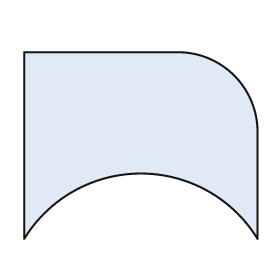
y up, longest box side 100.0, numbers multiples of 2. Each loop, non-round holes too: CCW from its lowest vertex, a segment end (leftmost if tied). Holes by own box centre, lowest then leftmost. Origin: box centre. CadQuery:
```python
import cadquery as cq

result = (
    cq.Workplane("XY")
    .moveTo(-50.0, -40.0)
    .threePointArc((0.0, -12.0), (50.0, -40.0))
    .lineTo(50.0, 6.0)
    .threePointArc((40.0, 30.0), (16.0, 40.0))
    .lineTo(-50.0, 40.0)
    .close()
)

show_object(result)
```